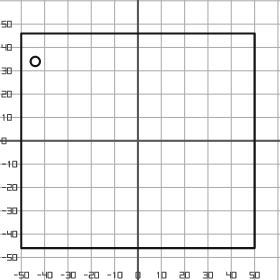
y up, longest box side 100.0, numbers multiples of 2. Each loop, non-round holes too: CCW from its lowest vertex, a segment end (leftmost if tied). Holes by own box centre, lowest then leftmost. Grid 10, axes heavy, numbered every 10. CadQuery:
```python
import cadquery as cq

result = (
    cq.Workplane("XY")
    .moveTo(-50.0, -46.0)
    .lineTo(50.0, -46.0)
    .lineTo(50.0, 46.0)
    .lineTo(-50.0, 46.0)
    .close()
    .moveTo(-44.0, 34.0)
    .circle(2.0)
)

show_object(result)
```